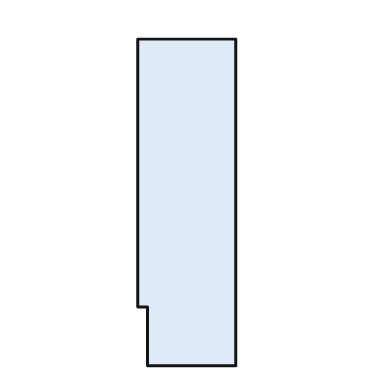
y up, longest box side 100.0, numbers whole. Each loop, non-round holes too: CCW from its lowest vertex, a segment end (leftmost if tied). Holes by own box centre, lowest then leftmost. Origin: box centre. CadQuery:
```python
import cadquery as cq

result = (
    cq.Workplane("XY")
    .moveTo(-12.0, -50.0)
    .lineTo(15.0, -50.0)
    .lineTo(15.0, 50.0)
    .lineTo(-15.0, 50.0)
    .lineTo(-15.0, -32.0)
    .lineTo(-12.0, -32.0)
    .close()
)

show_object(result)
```